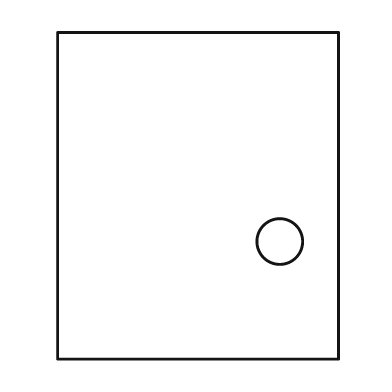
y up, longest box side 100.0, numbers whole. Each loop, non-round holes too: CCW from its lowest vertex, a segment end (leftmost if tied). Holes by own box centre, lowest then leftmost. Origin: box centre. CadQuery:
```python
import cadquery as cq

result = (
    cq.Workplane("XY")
    .moveTo(-43.0, -50.0)
    .lineTo(43.0, -50.0)
    .lineTo(43.0, 50.0)
    .lineTo(-43.0, 50.0)
    .close()
    .moveTo(25.0, -14.0)
    .circle(7.0)
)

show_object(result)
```